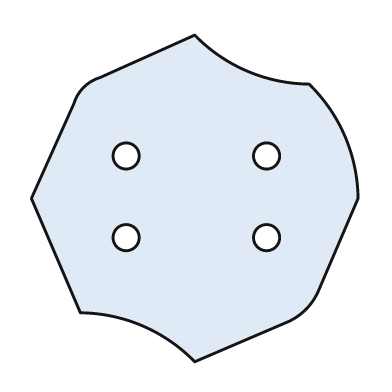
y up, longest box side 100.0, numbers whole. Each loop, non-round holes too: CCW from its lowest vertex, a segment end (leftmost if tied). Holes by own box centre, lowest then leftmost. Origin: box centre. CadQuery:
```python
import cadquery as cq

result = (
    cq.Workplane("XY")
    .moveTo(0.0, -50.0)
    .lineTo(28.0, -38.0)
    .threePointArc((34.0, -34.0), (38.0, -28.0))
    .lineTo(50.0, 0.0)
    .threePointArc((46.0, 19.0), (35.0, 35.0))
    .threePointArc((16.0, 39.0), (0.0, 50.0))
    .lineTo(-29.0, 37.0)
    .threePointArc((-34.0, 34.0), (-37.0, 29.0))
    .lineTo(-50.0, 0.0)
    .lineTo(-35.0, -35.0)
    .threePointArc((-16.0, -39.0), (0.0, -50.0))
    .close()
    .moveTo(-21.0, -12.0)
    .circle(4.0)
    .moveTo(22.0, -12.0)
    .circle(4.0)
    .moveTo(-21.0, 13.0)
    .circle(4.0)
    .moveTo(22.0, 13.0)
    .circle(4.0)
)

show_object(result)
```